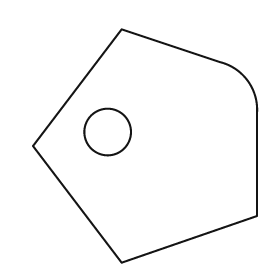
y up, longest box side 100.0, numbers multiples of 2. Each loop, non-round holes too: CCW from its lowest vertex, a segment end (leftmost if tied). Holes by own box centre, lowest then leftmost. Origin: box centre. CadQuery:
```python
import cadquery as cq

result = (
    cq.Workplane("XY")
    .moveTo(-10.0, -50.0)
    .lineTo(48.0, -30.0)
    .lineTo(48.0, 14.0)
    .threePointArc((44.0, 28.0), (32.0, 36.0))
    .lineTo(-10.0, 50.0)
    .lineTo(-48.0, 0.0)
    .close()
    .moveTo(-16.0, 6.0)
    .circle(10.0)
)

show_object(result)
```